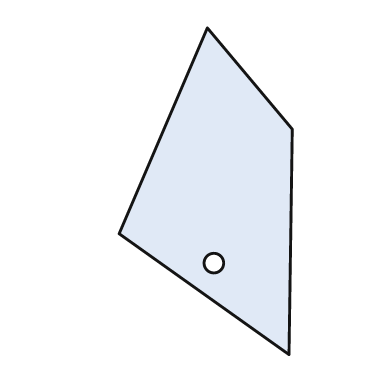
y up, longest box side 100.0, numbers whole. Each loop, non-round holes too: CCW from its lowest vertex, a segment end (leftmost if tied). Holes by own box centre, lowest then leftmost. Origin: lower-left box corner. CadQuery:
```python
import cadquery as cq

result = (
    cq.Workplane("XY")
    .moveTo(52.0, 0.0)
    .lineTo(53.0, 69.0)
    .lineTo(27.0, 100.0)
    .lineTo(0.0, 37.0)
    .close()
    .moveTo(29.0, 28.0)
    .circle(3.0)
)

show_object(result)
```